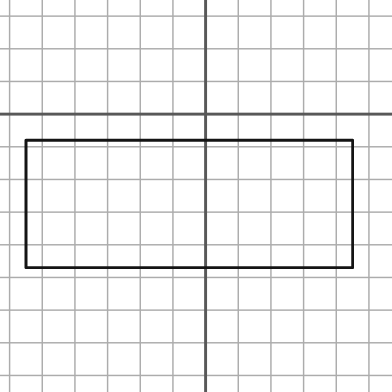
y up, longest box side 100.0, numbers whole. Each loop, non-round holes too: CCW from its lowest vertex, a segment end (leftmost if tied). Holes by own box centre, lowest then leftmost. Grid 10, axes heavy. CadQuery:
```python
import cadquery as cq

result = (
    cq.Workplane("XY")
    .moveTo(-55.0, -47.0)
    .lineTo(45.0, -47.0)
    .lineTo(45.0, -8.0)
    .lineTo(-55.0, -8.0)
    .close()
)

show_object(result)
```